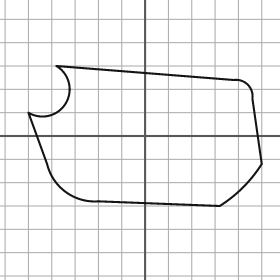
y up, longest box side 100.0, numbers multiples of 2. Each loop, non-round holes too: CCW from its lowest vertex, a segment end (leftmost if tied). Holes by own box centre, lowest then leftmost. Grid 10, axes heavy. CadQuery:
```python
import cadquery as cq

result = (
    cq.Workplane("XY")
    .moveTo(32.0, -30.0)
    .threePointArc((42.0, -22.0), (50.0, -12.0))
    .lineTo(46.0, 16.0)
    .threePointArc((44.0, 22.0), (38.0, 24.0))
    .lineTo(-38.0, 30.0)
    .threePointArc((-34.0, 14.0), (-50.0, 10.0))
    .lineTo(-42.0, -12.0)
    .threePointArc((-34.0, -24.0), (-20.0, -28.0))
    .close()
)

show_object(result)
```